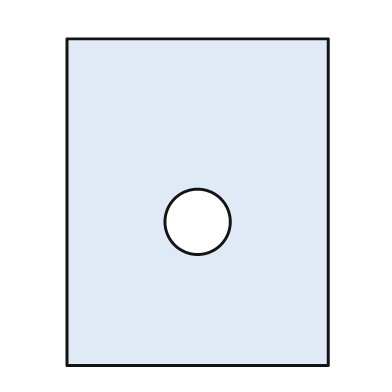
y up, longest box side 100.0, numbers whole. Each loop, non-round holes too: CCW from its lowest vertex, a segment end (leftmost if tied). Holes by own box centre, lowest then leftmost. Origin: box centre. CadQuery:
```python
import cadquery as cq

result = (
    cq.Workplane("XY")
    .moveTo(-40.0, -50.0)
    .lineTo(40.0, -50.0)
    .lineTo(40.0, 50.0)
    .lineTo(-40.0, 50.0)
    .close()
    .moveTo(0.0, -6.0)
    .circle(10.0)
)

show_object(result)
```